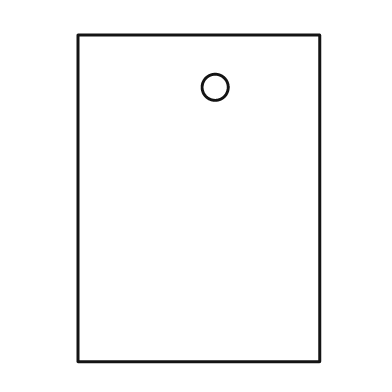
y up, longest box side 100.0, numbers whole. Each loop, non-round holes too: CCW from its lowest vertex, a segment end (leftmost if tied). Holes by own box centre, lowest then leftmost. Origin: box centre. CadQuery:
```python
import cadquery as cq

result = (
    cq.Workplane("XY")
    .moveTo(-37.0, -50.0)
    .lineTo(37.0, -50.0)
    .lineTo(37.0, 50.0)
    .lineTo(-37.0, 50.0)
    .close()
    .moveTo(5.0, 34.0)
    .circle(4.0)
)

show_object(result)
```